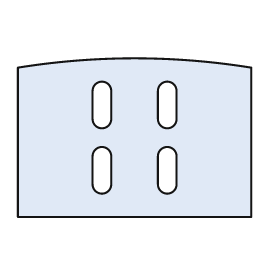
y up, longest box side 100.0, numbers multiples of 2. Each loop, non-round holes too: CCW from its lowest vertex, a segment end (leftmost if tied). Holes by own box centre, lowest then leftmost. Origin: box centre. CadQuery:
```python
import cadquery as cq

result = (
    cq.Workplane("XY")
    .moveTo(-50.0, -34.0)
    .lineTo(50.0, -34.0)
    .lineTo(50.0, 30.0)
    .threePointArc((0.0, 34.0), (-50.0, 30.0))
    .close()
    .moveTo(-18.0, -20.0)
    .threePointArc((-14.0, -24.0), (-10.0, -20.0))
    .lineTo(-10.0, -8.0)
    .threePointArc((-14.0, -4.0), (-18.0, -8.0))
    .close()
    .moveTo(10.0, -20.0)
    .threePointArc((14.0, -24.0), (18.0, -20.0))
    .lineTo(18.0, -8.0)
    .threePointArc((14.0, -4.0), (10.0, -8.0))
    .close()
    .moveTo(-18.0, 8.0)
    .threePointArc((-14.0, 4.0), (-10.0, 8.0))
    .lineTo(-10.0, 20.0)
    .threePointArc((-14.0, 24.0), (-18.0, 20.0))
    .close()
    .moveTo(10.0, 8.0)
    .threePointArc((14.0, 4.0), (18.0, 8.0))
    .lineTo(18.0, 20.0)
    .threePointArc((14.0, 24.0), (10.0, 20.0))
    .close()
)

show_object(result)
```